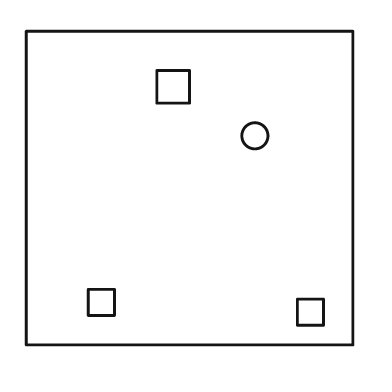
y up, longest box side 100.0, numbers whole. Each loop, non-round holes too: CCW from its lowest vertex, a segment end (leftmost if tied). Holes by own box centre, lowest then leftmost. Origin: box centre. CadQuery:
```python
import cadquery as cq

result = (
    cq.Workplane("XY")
    .moveTo(-50.0, -48.0)
    .lineTo(50.0, -48.0)
    .lineTo(50.0, 48.0)
    .lineTo(-50.0, 48.0)
    .close()
    .moveTo(33.0, -42.0)
    .lineTo(41.0, -42.0)
    .lineTo(41.0, -34.0)
    .lineTo(33.0, -34.0)
    .close()
    .moveTo(-31.0, -39.0)
    .lineTo(-23.0, -39.0)
    .lineTo(-23.0, -31.0)
    .lineTo(-31.0, -31.0)
    .close()
    .moveTo(20.0, 16.0)
    .circle(4.0)
    .moveTo(-10.0, 26.0)
    .lineTo(0.0, 26.0)
    .lineTo(0.0, 36.0)
    .lineTo(-10.0, 36.0)
    .close()
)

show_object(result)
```